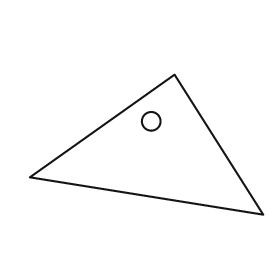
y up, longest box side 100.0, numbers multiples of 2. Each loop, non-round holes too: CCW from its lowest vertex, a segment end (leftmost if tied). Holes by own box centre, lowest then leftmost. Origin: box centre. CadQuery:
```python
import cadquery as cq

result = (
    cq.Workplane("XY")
    .moveTo(50.0, -30.0)
    .lineTo(12.0, 30.0)
    .lineTo(-50.0, -14.0)
    .close()
    .moveTo(2.0, 10.0)
    .circle(4.0)
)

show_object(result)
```